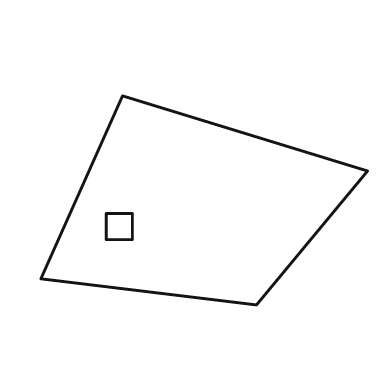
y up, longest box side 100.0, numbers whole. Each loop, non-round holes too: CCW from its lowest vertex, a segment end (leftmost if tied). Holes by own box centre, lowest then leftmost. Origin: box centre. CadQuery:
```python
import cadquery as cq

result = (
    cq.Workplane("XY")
    .moveTo(16.0, -32.0)
    .lineTo(50.0, 9.0)
    .lineTo(-25.0, 32.0)
    .lineTo(-50.0, -24.0)
    .close()
    .moveTo(-30.0, -12.0)
    .lineTo(-22.0, -12.0)
    .lineTo(-22.0, -4.0)
    .lineTo(-30.0, -4.0)
    .close()
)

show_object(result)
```